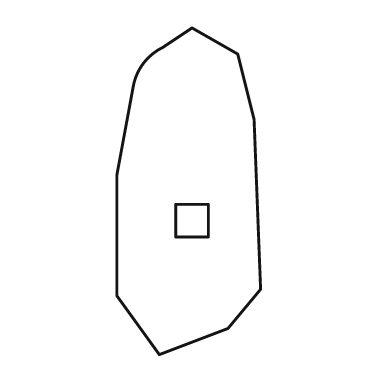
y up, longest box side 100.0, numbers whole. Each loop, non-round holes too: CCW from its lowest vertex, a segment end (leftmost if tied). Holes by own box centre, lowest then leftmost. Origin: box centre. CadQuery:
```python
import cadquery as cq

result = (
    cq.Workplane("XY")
    .moveTo(-9.0, -50.0)
    .lineTo(12.0, -42.0)
    .lineTo(22.0, -30.0)
    .lineTo(20.0, 22.0)
    .lineTo(15.0, 42.0)
    .lineTo(1.0, 50.0)
    .lineTo(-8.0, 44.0)
    .threePointArc((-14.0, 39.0), (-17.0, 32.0))
    .lineTo(-22.0, 5.0)
    .lineTo(-22.0, -32.0)
    .close()
    .moveTo(-4.0, -14.0)
    .lineTo(6.0, -14.0)
    .lineTo(6.0, -4.0)
    .lineTo(-4.0, -4.0)
    .close()
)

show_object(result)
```